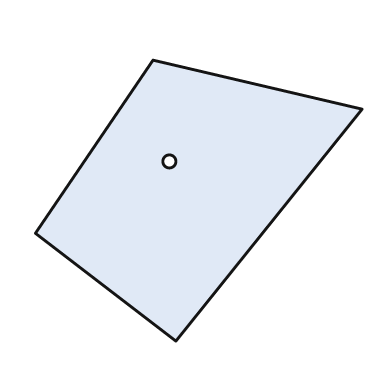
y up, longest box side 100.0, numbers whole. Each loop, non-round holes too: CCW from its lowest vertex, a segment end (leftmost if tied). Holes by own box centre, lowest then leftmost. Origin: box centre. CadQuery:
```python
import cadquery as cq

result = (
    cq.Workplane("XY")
    .moveTo(-7.0, -43.0)
    .lineTo(50.0, 28.0)
    .lineTo(-14.0, 43.0)
    .lineTo(-50.0, -10.0)
    .close()
    .moveTo(-9.0, 12.0)
    .circle(2.0)
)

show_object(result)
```